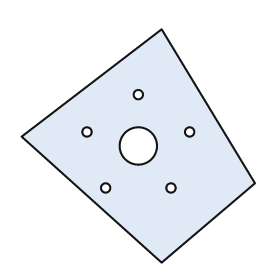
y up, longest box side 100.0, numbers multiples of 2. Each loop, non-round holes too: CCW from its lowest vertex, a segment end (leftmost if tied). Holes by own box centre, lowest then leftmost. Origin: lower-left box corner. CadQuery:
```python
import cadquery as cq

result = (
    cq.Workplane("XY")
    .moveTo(60.0, 0.0)
    .lineTo(100.0, 34.0)
    .lineTo(60.0, 100.0)
    .lineTo(0.0, 54.0)
    .close()
    .moveTo(36.0, 32.0)
    .circle(2.0)
    .moveTo(64.0, 32.0)
    .circle(2.0)
    .moveTo(50.0, 50.0)
    .circle(8.0)
    .moveTo(28.0, 56.0)
    .circle(2.0)
    .moveTo(72.0, 56.0)
    .circle(2.0)
    .moveTo(50.0, 72.0)
    .circle(2.0)
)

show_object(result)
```